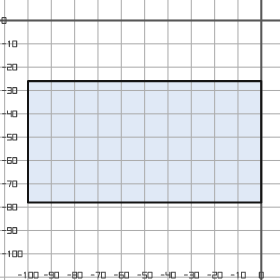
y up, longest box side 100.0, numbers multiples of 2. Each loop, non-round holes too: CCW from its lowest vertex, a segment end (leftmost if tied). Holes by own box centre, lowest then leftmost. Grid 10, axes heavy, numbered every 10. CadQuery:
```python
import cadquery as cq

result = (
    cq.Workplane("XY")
    .moveTo(-100.0, -78.0)
    .lineTo(0.0, -78.0)
    .lineTo(0.0, -26.0)
    .lineTo(-100.0, -26.0)
    .close()
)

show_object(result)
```